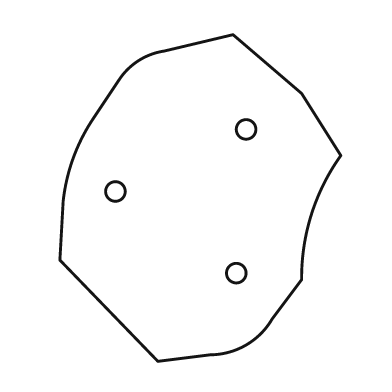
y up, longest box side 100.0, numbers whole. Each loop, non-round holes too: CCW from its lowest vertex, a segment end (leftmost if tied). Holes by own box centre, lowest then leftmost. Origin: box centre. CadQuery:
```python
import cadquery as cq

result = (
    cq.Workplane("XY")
    .moveTo(-13.0, -50.0)
    .lineTo(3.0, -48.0)
    .threePointArc((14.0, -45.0), (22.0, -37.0))
    .lineTo(31.0, -25.0)
    .threePointArc((34.0, -5.0), (43.0, 13.0))
    .lineTo(31.0, 32.0)
    .lineTo(10.0, 50.0)
    .lineTo(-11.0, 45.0)
    .threePointArc((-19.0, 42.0), (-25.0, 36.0))
    .lineTo(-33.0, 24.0)
    .threePointArc((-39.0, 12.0), (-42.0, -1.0))
    .lineTo(-43.0, -19.0)
    .close()
    .moveTo(11.0, -23.0)
    .circle(3.0)
    .moveTo(-26.0, 2.0)
    .circle(3.0)
    .moveTo(14.0, 21.0)
    .circle(3.0)
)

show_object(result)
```